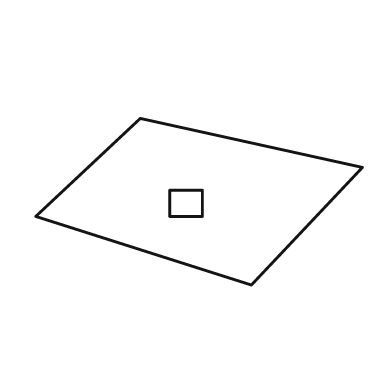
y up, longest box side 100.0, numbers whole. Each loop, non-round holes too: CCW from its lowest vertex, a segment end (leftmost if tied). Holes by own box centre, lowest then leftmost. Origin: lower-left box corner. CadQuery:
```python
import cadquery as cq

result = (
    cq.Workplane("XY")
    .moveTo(66.0, 0.0)
    .lineTo(100.0, 36.0)
    .lineTo(32.0, 51.0)
    .lineTo(0.0, 21.0)
    .close()
    .moveTo(41.0, 21.0)
    .lineTo(51.0, 21.0)
    .lineTo(51.0, 29.0)
    .lineTo(41.0, 29.0)
    .close()
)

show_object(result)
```